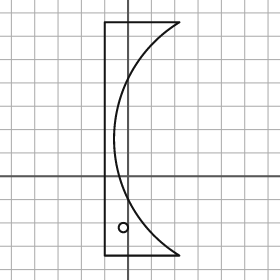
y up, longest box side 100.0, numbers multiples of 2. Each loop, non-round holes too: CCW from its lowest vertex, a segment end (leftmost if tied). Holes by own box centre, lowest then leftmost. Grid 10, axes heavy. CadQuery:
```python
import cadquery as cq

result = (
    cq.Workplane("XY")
    .moveTo(-10.0, -34.0)
    .lineTo(22.0, -34.0)
    .threePointArc((-6.0, 16.0), (22.0, 66.0))
    .lineTo(-10.0, 66.0)
    .close()
    .moveTo(-2.0, -22.0)
    .circle(2.0)
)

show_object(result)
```